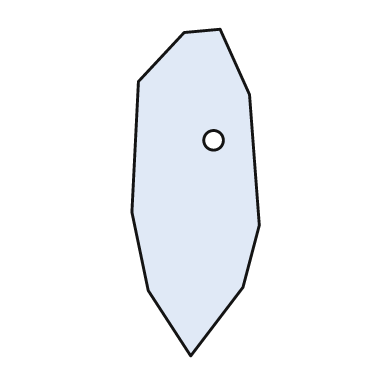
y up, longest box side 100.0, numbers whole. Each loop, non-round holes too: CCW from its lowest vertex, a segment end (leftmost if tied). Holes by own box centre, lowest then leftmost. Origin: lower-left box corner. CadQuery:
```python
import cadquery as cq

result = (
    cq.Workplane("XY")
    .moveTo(18.0, 0.0)
    .lineTo(34.0, 21.0)
    .lineTo(39.0, 40.0)
    .lineTo(36.0, 80.0)
    .lineTo(27.0, 100.0)
    .lineTo(16.0, 99.0)
    .lineTo(2.0, 84.0)
    .lineTo(0.0, 44.0)
    .lineTo(5.0, 20.0)
    .close()
    .moveTo(25.0, 66.0)
    .circle(3.0)
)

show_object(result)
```